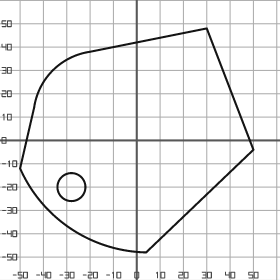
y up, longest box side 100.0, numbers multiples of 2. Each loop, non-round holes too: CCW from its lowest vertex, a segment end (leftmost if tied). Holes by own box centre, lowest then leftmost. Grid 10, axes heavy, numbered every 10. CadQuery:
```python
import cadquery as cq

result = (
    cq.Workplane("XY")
    .moveTo(4.0, -48.0)
    .lineTo(50.0, -4.0)
    .lineTo(30.0, 48.0)
    .lineTo(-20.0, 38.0)
    .threePointArc((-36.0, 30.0), (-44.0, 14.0))
    .lineTo(-50.0, -12.0)
    .threePointArc((-28.0, -38.0), (4.0, -48.0))
    .close()
    .moveTo(-28.0, -20.0)
    .circle(6.0)
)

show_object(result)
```